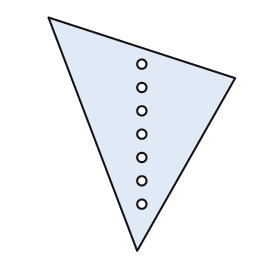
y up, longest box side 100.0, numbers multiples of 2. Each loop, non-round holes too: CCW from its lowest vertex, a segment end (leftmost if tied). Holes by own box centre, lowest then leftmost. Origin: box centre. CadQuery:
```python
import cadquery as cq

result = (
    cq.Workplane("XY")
    .moveTo(-2.0, -50.0)
    .lineTo(40.0, 24.0)
    .lineTo(-40.0, 50.0)
    .close()
    .moveTo(0.0, -30.0)
    .circle(2.0)
    .moveTo(0.0, -20.0)
    .circle(2.0)
    .moveTo(0.0, -10.0)
    .circle(2.0)
    .moveTo(0.0, 0.0)
    .circle(2.0)
    .moveTo(0.0, 10.0)
    .circle(2.0)
    .moveTo(0.0, 20.0)
    .circle(2.0)
    .moveTo(0.0, 30.0)
    .circle(2.0)
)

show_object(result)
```